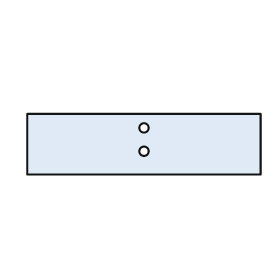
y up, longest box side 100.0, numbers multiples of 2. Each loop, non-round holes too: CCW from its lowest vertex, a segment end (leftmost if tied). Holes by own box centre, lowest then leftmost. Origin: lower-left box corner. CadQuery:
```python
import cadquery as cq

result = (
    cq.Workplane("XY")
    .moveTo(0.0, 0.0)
    .lineTo(100.0, 0.0)
    .lineTo(100.0, 26.0)
    .lineTo(0.0, 26.0)
    .close()
    .moveTo(50.0, 10.0)
    .circle(2.0)
    .moveTo(50.0, 20.0)
    .circle(2.0)
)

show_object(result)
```